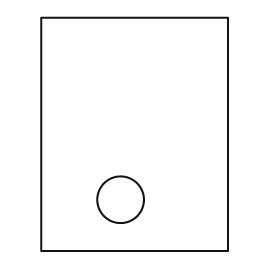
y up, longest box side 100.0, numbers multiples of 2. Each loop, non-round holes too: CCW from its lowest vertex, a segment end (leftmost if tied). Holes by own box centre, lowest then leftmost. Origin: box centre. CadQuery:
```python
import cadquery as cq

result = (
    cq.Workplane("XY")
    .moveTo(-40.0, -50.0)
    .lineTo(40.0, -50.0)
    .lineTo(40.0, 50.0)
    .lineTo(-40.0, 50.0)
    .close()
    .moveTo(-6.0, -28.0)
    .circle(10.0)
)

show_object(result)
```